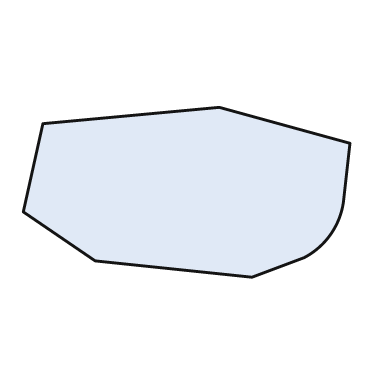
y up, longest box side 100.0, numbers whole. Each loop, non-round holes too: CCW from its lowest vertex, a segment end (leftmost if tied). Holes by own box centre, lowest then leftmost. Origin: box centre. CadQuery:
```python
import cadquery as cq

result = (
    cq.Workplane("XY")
    .moveTo(20.0, -26.0)
    .lineTo(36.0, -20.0)
    .threePointArc((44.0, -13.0), (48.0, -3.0))
    .lineTo(50.0, 15.0)
    .lineTo(10.0, 26.0)
    .lineTo(-44.0, 21.0)
    .lineTo(-50.0, -6.0)
    .lineTo(-28.0, -21.0)
    .close()
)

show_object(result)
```